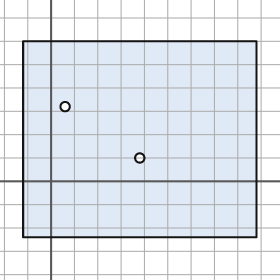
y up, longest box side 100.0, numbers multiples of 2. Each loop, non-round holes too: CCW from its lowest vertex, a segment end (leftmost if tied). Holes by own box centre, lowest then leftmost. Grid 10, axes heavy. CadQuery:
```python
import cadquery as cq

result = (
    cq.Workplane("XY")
    .moveTo(-12.0, -24.0)
    .lineTo(88.0, -24.0)
    .lineTo(88.0, 60.0)
    .lineTo(-12.0, 60.0)
    .close()
    .moveTo(38.0, 10.0)
    .circle(2.0)
    .moveTo(6.0, 32.0)
    .circle(2.0)
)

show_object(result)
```